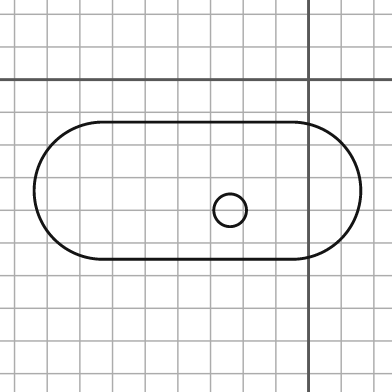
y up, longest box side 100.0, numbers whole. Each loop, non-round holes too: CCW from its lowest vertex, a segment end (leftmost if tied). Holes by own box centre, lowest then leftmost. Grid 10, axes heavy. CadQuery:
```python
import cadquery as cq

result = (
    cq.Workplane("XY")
    .moveTo(-63.0, -55.0)
    .lineTo(-5.0, -55.0)
    .threePointArc((16.0, -34.0), (-5.0, -13.0))
    .lineTo(-63.0, -13.0)
    .threePointArc((-84.0, -34.0), (-63.0, -55.0))
    .close()
    .moveTo(-24.0, -40.0)
    .circle(5.0)
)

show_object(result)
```